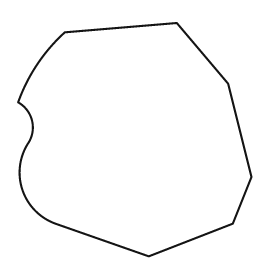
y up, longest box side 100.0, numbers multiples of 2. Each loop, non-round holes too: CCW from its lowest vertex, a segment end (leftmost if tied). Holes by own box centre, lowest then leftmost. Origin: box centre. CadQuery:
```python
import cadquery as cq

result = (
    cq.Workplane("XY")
    .moveTo(6.0, -50.0)
    .lineTo(42.0, -36.0)
    .lineTo(50.0, -16.0)
    .lineTo(40.0, 24.0)
    .lineTo(18.0, 50.0)
    .lineTo(-30.0, 46.0)
    .threePointArc((-42.0, 32.0), (-50.0, 16.0))
    .threePointArc((-44.0, 8.0), (-46.0, -2.0))
    .threePointArc((-48.0, -22.0), (-34.0, -36.0))
    .close()
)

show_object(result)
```